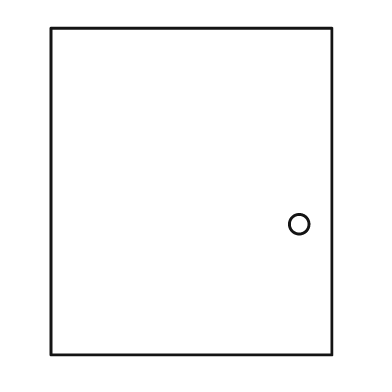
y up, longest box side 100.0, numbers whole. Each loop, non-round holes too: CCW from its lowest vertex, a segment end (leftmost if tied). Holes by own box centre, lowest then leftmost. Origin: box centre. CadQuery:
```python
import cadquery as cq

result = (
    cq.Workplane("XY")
    .moveTo(-43.0, -50.0)
    .lineTo(43.0, -50.0)
    .lineTo(43.0, 50.0)
    .lineTo(-43.0, 50.0)
    .close()
    .moveTo(33.0, -10.0)
    .circle(3.0)
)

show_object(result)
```